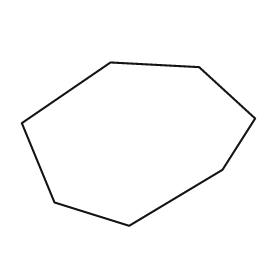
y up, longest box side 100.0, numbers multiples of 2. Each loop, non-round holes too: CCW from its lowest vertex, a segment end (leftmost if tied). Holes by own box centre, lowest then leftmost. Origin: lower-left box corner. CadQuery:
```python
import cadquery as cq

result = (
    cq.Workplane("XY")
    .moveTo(46.0, 0.0)
    .lineTo(86.0, 24.0)
    .lineTo(100.0, 46.0)
    .lineTo(76.0, 68.0)
    .lineTo(38.0, 70.0)
    .lineTo(0.0, 44.0)
    .lineTo(14.0, 10.0)
    .close()
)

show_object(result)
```